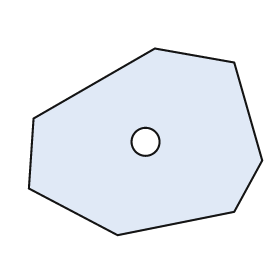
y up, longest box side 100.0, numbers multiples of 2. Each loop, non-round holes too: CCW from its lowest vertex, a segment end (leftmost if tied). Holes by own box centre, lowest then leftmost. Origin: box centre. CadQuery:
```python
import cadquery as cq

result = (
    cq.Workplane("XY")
    .moveTo(-12.0, -40.0)
    .lineTo(38.0, -30.0)
    .lineTo(50.0, -8.0)
    .lineTo(38.0, 34.0)
    .lineTo(4.0, 40.0)
    .lineTo(-48.0, 10.0)
    .lineTo(-50.0, -20.0)
    .close()
    .moveTo(0.0, 0.0)
    .circle(6.0)
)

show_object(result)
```